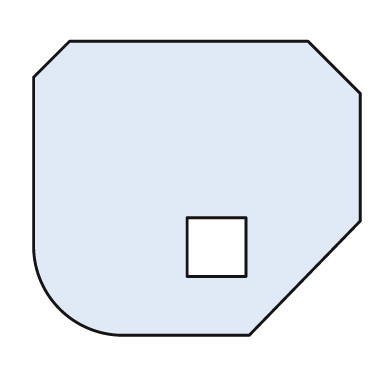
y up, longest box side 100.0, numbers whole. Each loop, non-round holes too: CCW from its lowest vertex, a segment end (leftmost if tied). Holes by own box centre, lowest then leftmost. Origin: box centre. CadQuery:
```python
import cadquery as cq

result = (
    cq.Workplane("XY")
    .moveTo(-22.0, -45.0)
    .lineTo(16.0, -45.0)
    .lineTo(50.0, -10.0)
    .lineTo(50.0, 29.0)
    .lineTo(34.0, 45.0)
    .lineTo(-39.0, 45.0)
    .lineTo(-50.0, 34.0)
    .lineTo(-50.0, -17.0)
    .threePointArc((-42.0, -37.0), (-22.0, -45.0))
    .close()
    .moveTo(-3.0, -27.0)
    .lineTo(15.0, -27.0)
    .lineTo(15.0, -9.0)
    .lineTo(-3.0, -9.0)
    .close()
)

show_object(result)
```